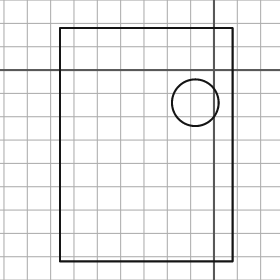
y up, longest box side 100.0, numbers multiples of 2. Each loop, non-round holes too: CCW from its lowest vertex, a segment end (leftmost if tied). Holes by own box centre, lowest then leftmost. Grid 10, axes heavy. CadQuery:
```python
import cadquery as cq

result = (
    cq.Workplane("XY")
    .moveTo(-66.0, -82.0)
    .lineTo(8.0, -82.0)
    .lineTo(8.0, 18.0)
    .lineTo(-66.0, 18.0)
    .close()
    .moveTo(-8.0, -14.0)
    .circle(10.0)
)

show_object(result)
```